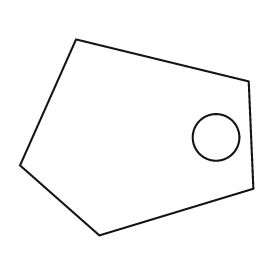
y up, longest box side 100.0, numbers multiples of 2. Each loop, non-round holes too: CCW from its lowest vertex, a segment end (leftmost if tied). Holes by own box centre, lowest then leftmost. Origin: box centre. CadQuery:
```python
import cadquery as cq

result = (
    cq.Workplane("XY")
    .moveTo(-16.0, -42.0)
    .lineTo(50.0, -22.0)
    .lineTo(48.0, 24.0)
    .lineTo(-26.0, 42.0)
    .lineTo(-50.0, -12.0)
    .close()
    .moveTo(34.0, 0.0)
    .circle(10.0)
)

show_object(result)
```